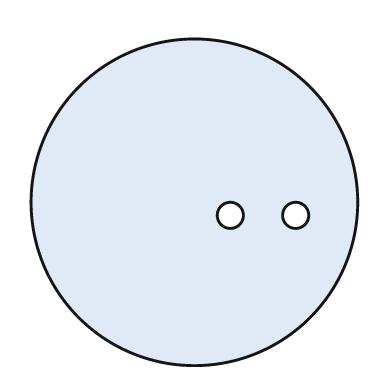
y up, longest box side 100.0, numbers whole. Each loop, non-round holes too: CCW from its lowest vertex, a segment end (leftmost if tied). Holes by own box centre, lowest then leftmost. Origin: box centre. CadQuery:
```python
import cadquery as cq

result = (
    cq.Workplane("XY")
    .moveTo(0.0, 0.0)
    .circle(50.0)
    .moveTo(11.0, -4.0)
    .circle(4.0)
    .moveTo(31.0, -4.0)
    .circle(4.0)
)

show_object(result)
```